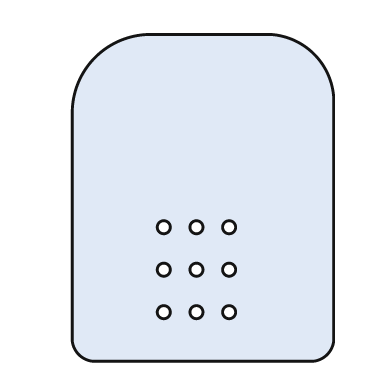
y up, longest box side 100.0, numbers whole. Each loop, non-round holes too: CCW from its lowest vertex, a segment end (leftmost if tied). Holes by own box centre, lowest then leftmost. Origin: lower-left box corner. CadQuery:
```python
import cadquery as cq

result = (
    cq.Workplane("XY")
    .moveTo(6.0, 0.0)
    .lineTo(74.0, 0.0)
    .threePointArc((78.0, 2.0), (80.0, 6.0))
    .lineTo(80.0, 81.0)
    .threePointArc((74.0, 94.0), (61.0, 100.0))
    .lineTo(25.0, 100.0)
    .threePointArc((7.0, 93.0), (0.0, 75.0))
    .lineTo(0.0, 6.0)
    .threePointArc((2.0, 2.0), (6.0, 0.0))
    .close()
    .moveTo(28.0, 15.0)
    .circle(2.0)
    .moveTo(38.0, 15.0)
    .circle(2.0)
    .moveTo(48.0, 15.0)
    .circle(2.0)
    .moveTo(28.0, 28.0)
    .circle(2.0)
    .moveTo(38.0, 28.0)
    .circle(2.0)
    .moveTo(48.0, 28.0)
    .circle(2.0)
    .moveTo(28.0, 41.0)
    .circle(2.0)
    .moveTo(38.0, 41.0)
    .circle(2.0)
    .moveTo(48.0, 41.0)
    .circle(2.0)
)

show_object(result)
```